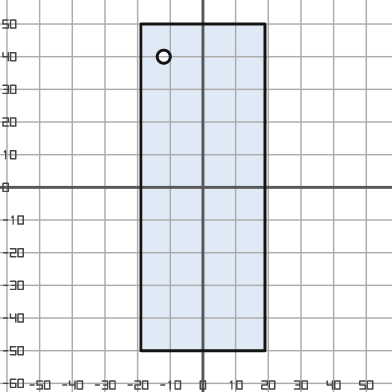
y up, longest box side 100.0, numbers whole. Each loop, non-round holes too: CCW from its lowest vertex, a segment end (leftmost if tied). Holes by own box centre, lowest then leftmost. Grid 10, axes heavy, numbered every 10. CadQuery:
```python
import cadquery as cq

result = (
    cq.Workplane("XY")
    .moveTo(-19.0, -50.0)
    .lineTo(19.0, -50.0)
    .lineTo(19.0, 50.0)
    .lineTo(-19.0, 50.0)
    .close()
    .moveTo(-12.0, 40.0)
    .circle(2.0)
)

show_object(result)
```